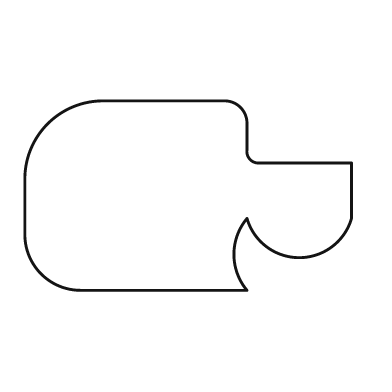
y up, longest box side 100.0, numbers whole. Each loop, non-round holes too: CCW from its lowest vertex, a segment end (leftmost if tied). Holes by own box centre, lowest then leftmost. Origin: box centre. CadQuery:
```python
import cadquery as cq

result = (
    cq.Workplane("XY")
    .moveTo(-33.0, -29.0)
    .lineTo(18.0, -29.0)
    .threePointArc((14.0, -18.0), (18.0, -7.0))
    .threePointArc((34.0, -19.0), (50.0, -7.0))
    .lineTo(50.0, 10.0)
    .lineTo(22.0, 10.0)
    .threePointArc((19.0, 11.0), (18.0, 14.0))
    .lineTo(18.0, 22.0)
    .threePointArc((16.0, 27.0), (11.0, 29.0))
    .lineTo(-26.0, 29.0)
    .threePointArc((-43.0, 22.0), (-50.0, 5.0))
    .lineTo(-50.0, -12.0)
    .threePointArc((-45.0, -24.0), (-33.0, -29.0))
    .close()
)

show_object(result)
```